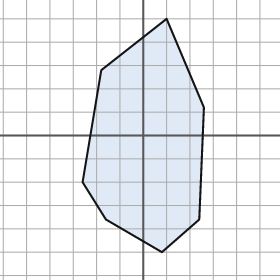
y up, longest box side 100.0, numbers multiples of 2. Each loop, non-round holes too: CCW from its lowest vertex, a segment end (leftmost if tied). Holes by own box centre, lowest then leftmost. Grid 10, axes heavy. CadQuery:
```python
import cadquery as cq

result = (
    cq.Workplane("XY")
    .moveTo(8.0, -50.0)
    .lineTo(24.0, -36.0)
    .lineTo(26.0, 12.0)
    .lineTo(10.0, 50.0)
    .lineTo(-18.0, 28.0)
    .lineTo(-26.0, -20.0)
    .lineTo(-16.0, -36.0)
    .close()
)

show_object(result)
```